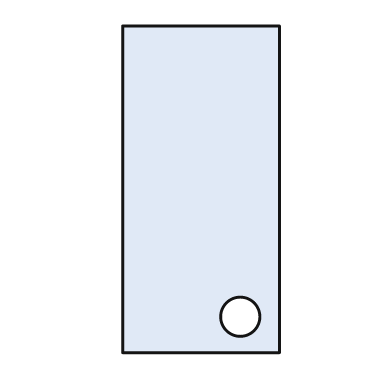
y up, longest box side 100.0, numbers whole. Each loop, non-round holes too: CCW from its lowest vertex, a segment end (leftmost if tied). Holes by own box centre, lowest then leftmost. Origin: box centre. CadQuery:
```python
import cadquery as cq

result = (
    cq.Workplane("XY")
    .moveTo(-24.0, -50.0)
    .lineTo(24.0, -50.0)
    .lineTo(24.0, 50.0)
    .lineTo(-24.0, 50.0)
    .close()
    .moveTo(12.0, -39.0)
    .circle(6.0)
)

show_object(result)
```